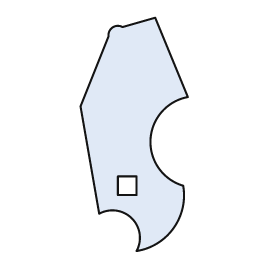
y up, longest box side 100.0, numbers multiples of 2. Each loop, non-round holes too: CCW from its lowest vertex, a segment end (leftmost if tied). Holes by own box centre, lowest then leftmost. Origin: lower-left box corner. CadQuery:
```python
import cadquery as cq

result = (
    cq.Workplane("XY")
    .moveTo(24.0, 0.0)
    .threePointArc((40.0, 10.0), (44.0, 28.0))
    .threePointArc((30.0, 48.0), (46.0, 66.0))
    .lineTo(32.0, 100.0)
    .lineTo(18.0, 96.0)
    .threePointArc((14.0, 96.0), (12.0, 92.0))
    .lineTo(0.0, 62.0)
    .lineTo(8.0, 16.0)
    .threePointArc((22.0, 14.0), (24.0, 0.0))
    .close()
    .moveTo(16.0, 24.0)
    .lineTo(24.0, 24.0)
    .lineTo(24.0, 32.0)
    .lineTo(16.0, 32.0)
    .close()
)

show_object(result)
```